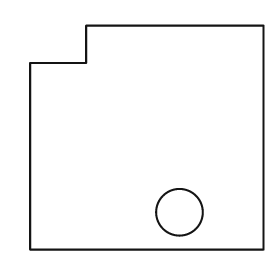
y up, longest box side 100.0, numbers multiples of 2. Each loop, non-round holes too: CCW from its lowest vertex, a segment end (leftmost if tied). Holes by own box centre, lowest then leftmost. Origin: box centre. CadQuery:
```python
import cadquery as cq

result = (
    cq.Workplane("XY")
    .moveTo(-50.0, -48.0)
    .lineTo(50.0, -48.0)
    .lineTo(50.0, 48.0)
    .lineTo(-26.0, 48.0)
    .lineTo(-26.0, 32.0)
    .lineTo(-50.0, 32.0)
    .close()
    .moveTo(14.0, -32.0)
    .circle(10.0)
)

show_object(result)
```